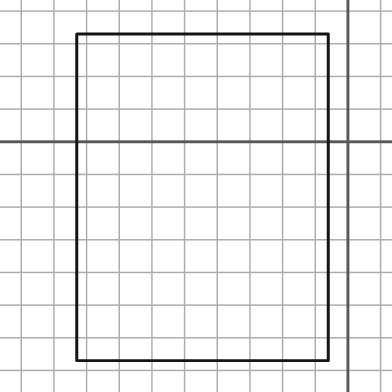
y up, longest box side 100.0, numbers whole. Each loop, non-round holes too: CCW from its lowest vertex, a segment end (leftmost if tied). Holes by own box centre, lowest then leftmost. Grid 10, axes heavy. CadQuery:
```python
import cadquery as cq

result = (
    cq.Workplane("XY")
    .moveTo(-83.0, -67.0)
    .lineTo(-6.0, -67.0)
    .lineTo(-6.0, 33.0)
    .lineTo(-83.0, 33.0)
    .close()
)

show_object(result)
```